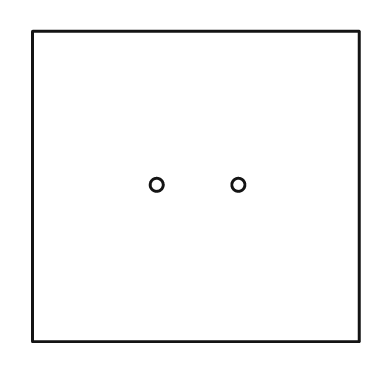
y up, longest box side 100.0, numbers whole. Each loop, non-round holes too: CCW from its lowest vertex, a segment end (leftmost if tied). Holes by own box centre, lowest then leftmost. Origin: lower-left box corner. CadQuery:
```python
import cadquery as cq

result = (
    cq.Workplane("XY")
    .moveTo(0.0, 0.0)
    .lineTo(100.0, 0.0)
    .lineTo(100.0, 95.0)
    .lineTo(0.0, 95.0)
    .close()
    .moveTo(38.0, 48.0)
    .circle(2.0)
    .moveTo(63.0, 48.0)
    .circle(2.0)
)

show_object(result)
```